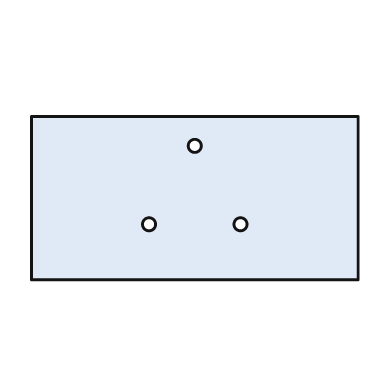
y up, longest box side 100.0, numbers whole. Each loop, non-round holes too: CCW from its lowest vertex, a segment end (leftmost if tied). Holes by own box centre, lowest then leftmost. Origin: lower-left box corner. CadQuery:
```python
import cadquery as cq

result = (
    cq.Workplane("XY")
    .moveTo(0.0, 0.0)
    .lineTo(100.0, 0.0)
    .lineTo(100.0, 50.0)
    .lineTo(0.0, 50.0)
    .close()
    .moveTo(36.0, 17.0)
    .circle(2.0)
    .moveTo(64.0, 17.0)
    .circle(2.0)
    .moveTo(50.0, 41.0)
    .circle(2.0)
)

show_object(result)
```